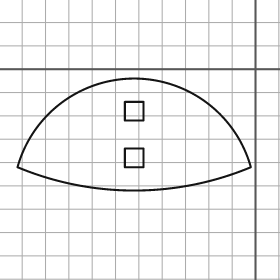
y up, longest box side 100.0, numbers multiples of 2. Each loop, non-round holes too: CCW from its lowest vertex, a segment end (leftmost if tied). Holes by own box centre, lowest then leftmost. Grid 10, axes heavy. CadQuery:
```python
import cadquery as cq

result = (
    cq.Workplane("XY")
    .moveTo(-102.0, -42.0)
    .threePointArc((-52.0, -52.0), (-2.0, -42.0))
    .threePointArc((-52.0, -4.0), (-102.0, -42.0))
    .close()
    .moveTo(-56.0, -42.0)
    .lineTo(-48.0, -42.0)
    .lineTo(-48.0, -34.0)
    .lineTo(-56.0, -34.0)
    .close()
    .moveTo(-56.0, -22.0)
    .lineTo(-48.0, -22.0)
    .lineTo(-48.0, -14.0)
    .lineTo(-56.0, -14.0)
    .close()
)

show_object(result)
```